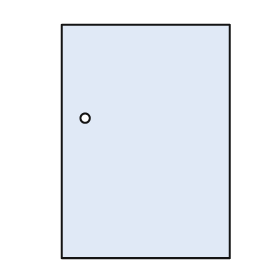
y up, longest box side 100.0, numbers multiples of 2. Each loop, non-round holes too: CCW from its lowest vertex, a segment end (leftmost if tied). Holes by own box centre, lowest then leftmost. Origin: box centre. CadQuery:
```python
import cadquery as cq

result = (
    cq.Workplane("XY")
    .moveTo(-36.0, -50.0)
    .lineTo(36.0, -50.0)
    .lineTo(36.0, 50.0)
    .lineTo(-36.0, 50.0)
    .close()
    .moveTo(-26.0, 10.0)
    .circle(2.0)
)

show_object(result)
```